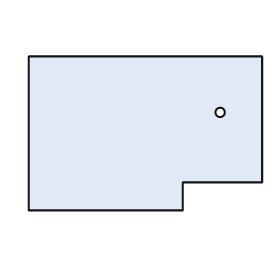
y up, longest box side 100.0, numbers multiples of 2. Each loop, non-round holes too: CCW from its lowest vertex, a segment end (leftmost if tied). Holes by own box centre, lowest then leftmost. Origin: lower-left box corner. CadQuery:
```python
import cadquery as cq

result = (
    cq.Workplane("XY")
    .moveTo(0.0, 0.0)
    .lineTo(66.0, 0.0)
    .lineTo(66.0, 12.0)
    .lineTo(100.0, 12.0)
    .lineTo(100.0, 66.0)
    .lineTo(0.0, 66.0)
    .close()
    .moveTo(82.0, 42.0)
    .circle(2.0)
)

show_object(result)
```